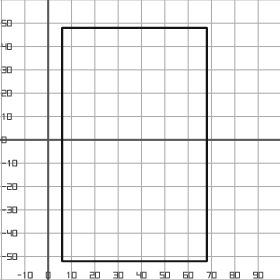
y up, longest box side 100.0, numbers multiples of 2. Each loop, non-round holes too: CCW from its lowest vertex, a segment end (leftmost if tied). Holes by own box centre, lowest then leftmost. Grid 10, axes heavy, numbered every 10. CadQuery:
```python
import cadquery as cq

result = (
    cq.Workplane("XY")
    .moveTo(6.0, -52.0)
    .lineTo(68.0, -52.0)
    .lineTo(68.0, 48.0)
    .lineTo(6.0, 48.0)
    .close()
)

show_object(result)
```